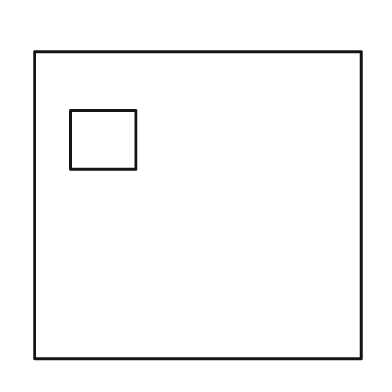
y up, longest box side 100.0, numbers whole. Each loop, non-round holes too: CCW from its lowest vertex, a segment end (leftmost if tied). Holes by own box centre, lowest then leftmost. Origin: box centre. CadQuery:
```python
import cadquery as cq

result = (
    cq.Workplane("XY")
    .moveTo(-50.0, -47.0)
    .lineTo(50.0, -47.0)
    .lineTo(50.0, 47.0)
    .lineTo(-50.0, 47.0)
    .close()
    .moveTo(-39.0, 11.0)
    .lineTo(-19.0, 11.0)
    .lineTo(-19.0, 29.0)
    .lineTo(-39.0, 29.0)
    .close()
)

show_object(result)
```